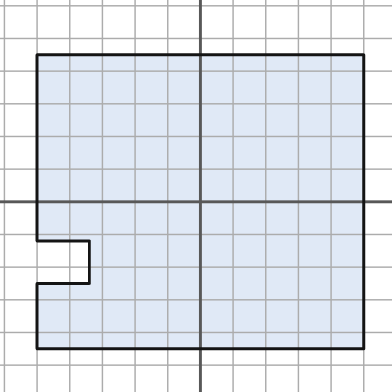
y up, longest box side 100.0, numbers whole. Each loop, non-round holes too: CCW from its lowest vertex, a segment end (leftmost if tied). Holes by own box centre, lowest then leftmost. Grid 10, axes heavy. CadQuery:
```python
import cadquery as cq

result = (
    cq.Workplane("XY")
    .moveTo(-50.0, -45.0)
    .lineTo(50.0, -45.0)
    .lineTo(50.0, 45.0)
    .lineTo(-50.0, 45.0)
    .lineTo(-50.0, -12.0)
    .lineTo(-34.0, -12.0)
    .lineTo(-34.0, -25.0)
    .lineTo(-50.0, -25.0)
    .close()
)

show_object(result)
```